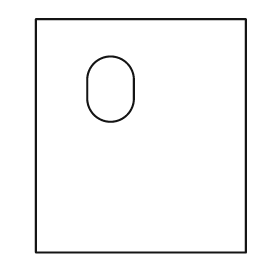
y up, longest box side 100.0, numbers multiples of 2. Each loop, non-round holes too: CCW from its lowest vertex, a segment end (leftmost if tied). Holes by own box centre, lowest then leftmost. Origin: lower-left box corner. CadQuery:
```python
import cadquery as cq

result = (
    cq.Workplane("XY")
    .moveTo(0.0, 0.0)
    .lineTo(90.0, 0.0)
    .lineTo(90.0, 100.0)
    .lineTo(0.0, 100.0)
    .close()
    .moveTo(22.0, 66.0)
    .threePointArc((32.0, 56.0), (42.0, 66.0))
    .lineTo(42.0, 74.0)
    .threePointArc((32.0, 84.0), (22.0, 74.0))
    .close()
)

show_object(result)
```